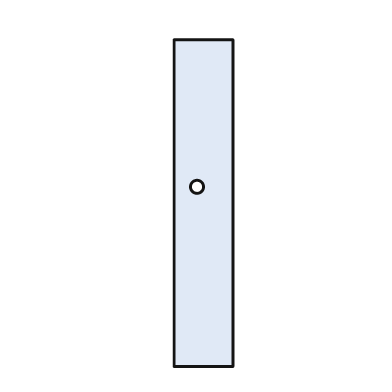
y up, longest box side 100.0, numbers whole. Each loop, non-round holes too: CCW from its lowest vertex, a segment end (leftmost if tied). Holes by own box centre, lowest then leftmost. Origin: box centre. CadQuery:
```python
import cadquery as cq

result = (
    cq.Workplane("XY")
    .moveTo(-9.0, -50.0)
    .lineTo(9.0, -50.0)
    .lineTo(9.0, 50.0)
    .lineTo(-9.0, 50.0)
    .close()
    .moveTo(-2.0, 5.0)
    .circle(2.0)
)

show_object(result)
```